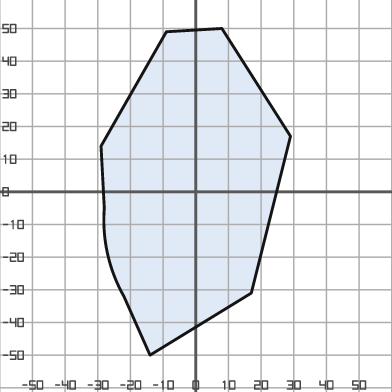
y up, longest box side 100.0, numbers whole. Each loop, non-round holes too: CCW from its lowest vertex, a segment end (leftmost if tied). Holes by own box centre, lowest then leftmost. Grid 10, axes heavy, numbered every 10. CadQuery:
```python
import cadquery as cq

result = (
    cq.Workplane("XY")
    .moveTo(-14.0, -50.0)
    .lineTo(17.0, -31.0)
    .lineTo(29.0, 17.0)
    .lineTo(8.0, 50.0)
    .lineTo(-9.0, 49.0)
    .lineTo(-29.0, 14.0)
    .lineTo(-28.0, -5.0)
    .threePointArc((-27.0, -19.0), (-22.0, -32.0))
    .close()
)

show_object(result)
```